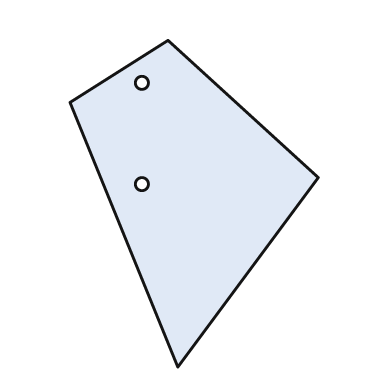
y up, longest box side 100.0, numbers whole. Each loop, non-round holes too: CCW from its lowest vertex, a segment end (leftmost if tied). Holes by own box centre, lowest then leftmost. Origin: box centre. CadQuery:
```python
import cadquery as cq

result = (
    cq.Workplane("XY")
    .moveTo(-5.0, -50.0)
    .lineTo(38.0, 8.0)
    .lineTo(-8.0, 50.0)
    .lineTo(-38.0, 31.0)
    .close()
    .moveTo(-16.0, 6.0)
    .circle(2.0)
    .moveTo(-16.0, 37.0)
    .circle(2.0)
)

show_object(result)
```